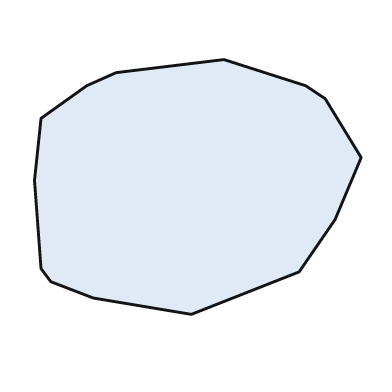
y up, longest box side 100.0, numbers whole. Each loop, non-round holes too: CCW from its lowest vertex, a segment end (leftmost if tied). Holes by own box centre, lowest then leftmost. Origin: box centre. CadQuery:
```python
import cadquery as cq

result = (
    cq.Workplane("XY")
    .moveTo(-2.0, -39.0)
    .lineTo(31.0, -26.0)
    .lineTo(42.0, -10.0)
    .lineTo(50.0, 9.0)
    .lineTo(39.0, 27.0)
    .lineTo(33.0, 31.0)
    .lineTo(8.0, 39.0)
    .lineTo(-25.0, 35.0)
    .lineTo(-34.0, 31.0)
    .lineTo(-48.0, 21.0)
    .lineTo(-50.0, 2.0)
    .lineTo(-48.0, -25.0)
    .lineTo(-45.0, -29.0)
    .lineTo(-32.0, -34.0)
    .close()
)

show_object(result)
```